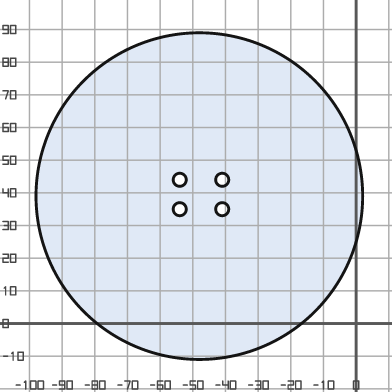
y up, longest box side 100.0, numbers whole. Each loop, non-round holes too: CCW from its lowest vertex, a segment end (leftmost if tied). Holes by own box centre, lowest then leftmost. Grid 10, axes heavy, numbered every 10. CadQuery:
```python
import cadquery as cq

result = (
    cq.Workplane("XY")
    .moveTo(-48.0, 39.0)
    .circle(50.0)
    .moveTo(-54.0, 35.0)
    .circle(2.0)
    .moveTo(-41.0, 35.0)
    .circle(2.0)
    .moveTo(-54.0, 44.0)
    .circle(2.0)
    .moveTo(-41.0, 44.0)
    .circle(2.0)
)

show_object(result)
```